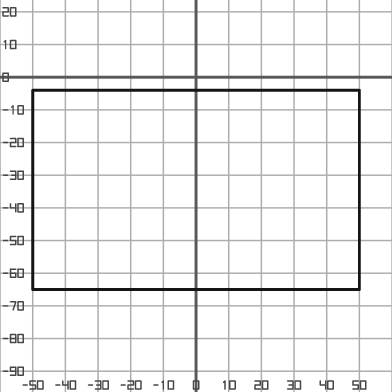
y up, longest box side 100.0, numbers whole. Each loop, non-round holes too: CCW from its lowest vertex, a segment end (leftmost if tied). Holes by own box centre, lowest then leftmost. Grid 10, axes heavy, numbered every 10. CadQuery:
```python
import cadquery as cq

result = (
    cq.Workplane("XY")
    .moveTo(-50.0, -65.0)
    .lineTo(50.0, -65.0)
    .lineTo(50.0, -4.0)
    .lineTo(-50.0, -4.0)
    .close()
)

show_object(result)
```